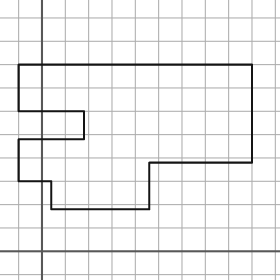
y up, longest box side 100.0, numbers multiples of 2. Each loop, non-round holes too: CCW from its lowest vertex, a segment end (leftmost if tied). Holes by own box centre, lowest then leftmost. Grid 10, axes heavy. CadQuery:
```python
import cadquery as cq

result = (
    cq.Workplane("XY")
    .moveTo(4.0, 18.0)
    .lineTo(46.0, 18.0)
    .lineTo(46.0, 38.0)
    .lineTo(90.0, 38.0)
    .lineTo(90.0, 80.0)
    .lineTo(-10.0, 80.0)
    .lineTo(-10.0, 60.0)
    .lineTo(18.0, 60.0)
    .lineTo(18.0, 48.0)
    .lineTo(-10.0, 48.0)
    .lineTo(-10.0, 30.0)
    .lineTo(4.0, 30.0)
    .close()
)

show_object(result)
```